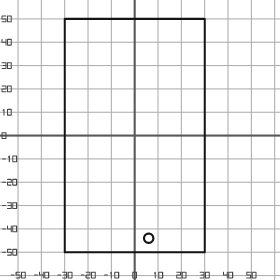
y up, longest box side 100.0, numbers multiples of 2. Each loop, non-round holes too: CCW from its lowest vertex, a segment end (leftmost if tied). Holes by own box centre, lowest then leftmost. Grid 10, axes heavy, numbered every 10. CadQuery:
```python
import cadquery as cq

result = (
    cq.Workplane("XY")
    .moveTo(-30.0, -50.0)
    .lineTo(30.0, -50.0)
    .lineTo(30.0, 50.0)
    .lineTo(-30.0, 50.0)
    .close()
    .moveTo(6.0, -44.0)
    .circle(2.0)
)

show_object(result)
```